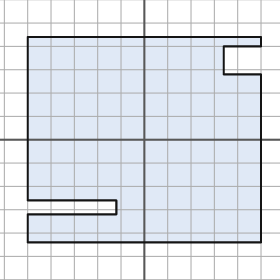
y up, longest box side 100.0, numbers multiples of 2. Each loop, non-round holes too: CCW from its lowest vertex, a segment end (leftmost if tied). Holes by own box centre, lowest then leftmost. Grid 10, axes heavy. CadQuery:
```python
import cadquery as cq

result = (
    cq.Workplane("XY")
    .moveTo(-50.0, -44.0)
    .lineTo(50.0, -44.0)
    .lineTo(50.0, 28.0)
    .lineTo(34.0, 28.0)
    .lineTo(34.0, 40.0)
    .lineTo(50.0, 40.0)
    .lineTo(50.0, 44.0)
    .lineTo(-50.0, 44.0)
    .lineTo(-50.0, -26.0)
    .lineTo(-12.0, -26.0)
    .lineTo(-12.0, -32.0)
    .lineTo(-50.0, -32.0)
    .close()
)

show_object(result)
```